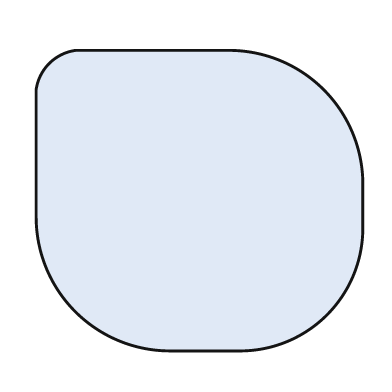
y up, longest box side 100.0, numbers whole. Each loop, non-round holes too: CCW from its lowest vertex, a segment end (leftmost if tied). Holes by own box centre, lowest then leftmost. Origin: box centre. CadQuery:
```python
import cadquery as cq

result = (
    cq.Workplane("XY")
    .moveTo(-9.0, -46.0)
    .lineTo(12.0, -46.0)
    .threePointArc((39.0, -35.0), (50.0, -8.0))
    .lineTo(50.0, 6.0)
    .threePointArc((38.0, 34.0), (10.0, 46.0))
    .lineTo(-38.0, 46.0)
    .threePointArc((-46.0, 42.0), (-50.0, 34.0))
    .lineTo(-50.0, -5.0)
    .threePointArc((-38.0, -34.0), (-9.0, -46.0))
    .close()
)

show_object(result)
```